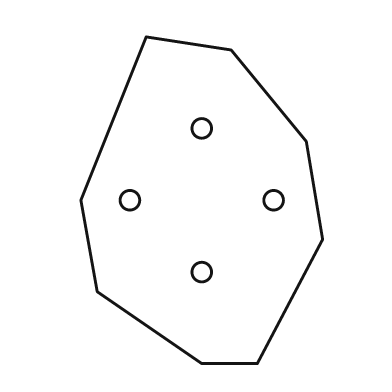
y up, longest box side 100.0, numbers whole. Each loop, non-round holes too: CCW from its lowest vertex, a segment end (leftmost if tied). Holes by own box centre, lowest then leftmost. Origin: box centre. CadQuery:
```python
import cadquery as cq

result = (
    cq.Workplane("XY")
    .moveTo(0.0, -50.0)
    .lineTo(17.0, -50.0)
    .lineTo(37.0, -12.0)
    .lineTo(32.0, 18.0)
    .lineTo(9.0, 46.0)
    .lineTo(-17.0, 50.0)
    .lineTo(-37.0, 0.0)
    .lineTo(-32.0, -28.0)
    .close()
    .moveTo(0.0, -22.0)
    .circle(3.0)
    .moveTo(-22.0, 0.0)
    .circle(3.0)
    .moveTo(22.0, 0.0)
    .circle(3.0)
    .moveTo(0.0, 22.0)
    .circle(3.0)
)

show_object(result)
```